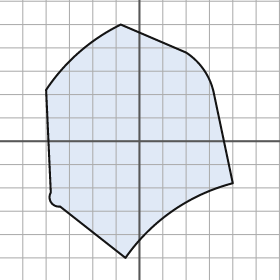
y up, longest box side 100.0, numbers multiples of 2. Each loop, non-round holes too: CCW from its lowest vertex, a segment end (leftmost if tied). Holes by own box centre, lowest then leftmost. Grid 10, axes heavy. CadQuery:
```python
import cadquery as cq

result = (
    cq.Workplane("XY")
    .moveTo(-6.0, -50.0)
    .threePointArc((14.0, -30.0), (40.0, -18.0))
    .lineTo(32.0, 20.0)
    .threePointArc((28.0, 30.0), (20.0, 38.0))
    .lineTo(-8.0, 50.0)
    .threePointArc((-26.0, 38.0), (-40.0, 22.0))
    .lineTo(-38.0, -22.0)
    .threePointArc((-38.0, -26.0), (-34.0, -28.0))
    .close()
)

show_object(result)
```